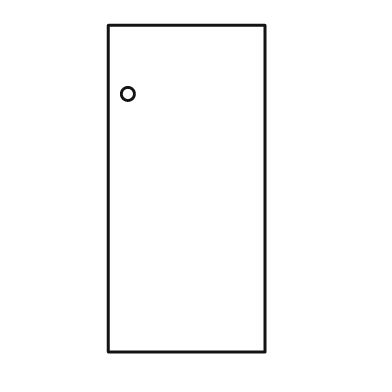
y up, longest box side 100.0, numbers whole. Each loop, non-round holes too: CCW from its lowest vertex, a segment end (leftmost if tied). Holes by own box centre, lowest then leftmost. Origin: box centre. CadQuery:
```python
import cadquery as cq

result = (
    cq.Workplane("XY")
    .moveTo(-24.0, -50.0)
    .lineTo(24.0, -50.0)
    .lineTo(24.0, 50.0)
    .lineTo(-24.0, 50.0)
    .close()
    .moveTo(-18.0, 29.0)
    .circle(2.0)
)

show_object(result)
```